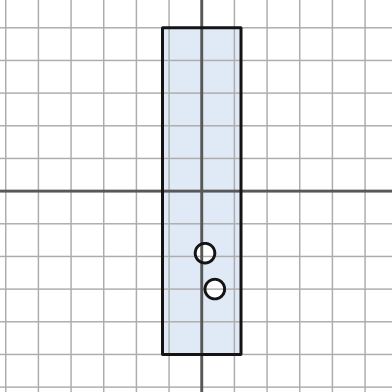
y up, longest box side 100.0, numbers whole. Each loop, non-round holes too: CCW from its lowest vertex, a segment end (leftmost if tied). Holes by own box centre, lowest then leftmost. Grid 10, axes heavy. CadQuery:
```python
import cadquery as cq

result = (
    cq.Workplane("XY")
    .moveTo(-12.0, -50.0)
    .lineTo(12.0, -50.0)
    .lineTo(12.0, 50.0)
    .lineTo(-12.0, 50.0)
    .close()
    .moveTo(4.0, -30.0)
    .circle(3.0)
    .moveTo(1.0, -19.0)
    .circle(3.0)
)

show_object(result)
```